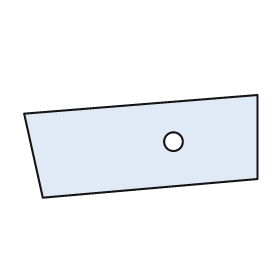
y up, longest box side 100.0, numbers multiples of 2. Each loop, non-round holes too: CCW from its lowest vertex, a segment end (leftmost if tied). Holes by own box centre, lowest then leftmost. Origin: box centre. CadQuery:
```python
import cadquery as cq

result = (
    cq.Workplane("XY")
    .moveTo(-42.0, -22.0)
    .lineTo(50.0, -14.0)
    .lineTo(50.0, 22.0)
    .lineTo(-50.0, 14.0)
    .close()
    .moveTo(14.0, 2.0)
    .circle(4.0)
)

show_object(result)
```